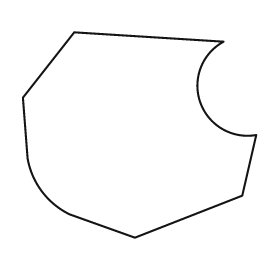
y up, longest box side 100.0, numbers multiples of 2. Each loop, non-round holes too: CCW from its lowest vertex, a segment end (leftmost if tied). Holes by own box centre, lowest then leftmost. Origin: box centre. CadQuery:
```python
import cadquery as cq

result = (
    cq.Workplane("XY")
    .moveTo(-2.0, -44.0)
    .lineTo(44.0, -26.0)
    .lineTo(50.0, 0.0)
    .threePointArc((26.0, 14.0), (36.0, 40.0))
    .lineTo(-28.0, 44.0)
    .lineTo(-50.0, 16.0)
    .lineTo(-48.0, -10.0)
    .threePointArc((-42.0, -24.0), (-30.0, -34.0))
    .close()
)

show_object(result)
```